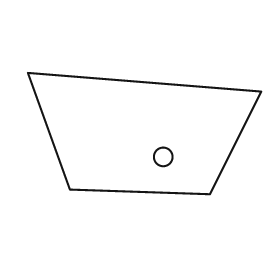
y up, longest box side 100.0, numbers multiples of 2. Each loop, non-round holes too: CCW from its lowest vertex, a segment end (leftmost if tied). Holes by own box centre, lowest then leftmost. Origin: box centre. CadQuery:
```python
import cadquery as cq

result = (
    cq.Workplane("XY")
    .moveTo(28.0, -26.0)
    .lineTo(50.0, 18.0)
    .lineTo(-50.0, 26.0)
    .lineTo(-32.0, -24.0)
    .close()
    .moveTo(8.0, -10.0)
    .circle(4.0)
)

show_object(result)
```